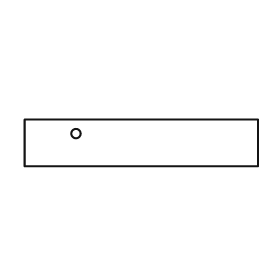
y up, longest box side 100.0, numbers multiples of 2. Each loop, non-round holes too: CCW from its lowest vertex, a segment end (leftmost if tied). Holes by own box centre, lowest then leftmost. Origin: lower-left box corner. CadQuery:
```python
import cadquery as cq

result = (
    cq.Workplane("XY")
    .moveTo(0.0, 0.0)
    .lineTo(100.0, 0.0)
    .lineTo(100.0, 20.0)
    .lineTo(0.0, 20.0)
    .close()
    .moveTo(22.0, 14.0)
    .circle(2.0)
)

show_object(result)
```